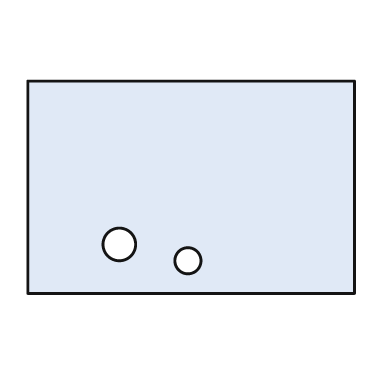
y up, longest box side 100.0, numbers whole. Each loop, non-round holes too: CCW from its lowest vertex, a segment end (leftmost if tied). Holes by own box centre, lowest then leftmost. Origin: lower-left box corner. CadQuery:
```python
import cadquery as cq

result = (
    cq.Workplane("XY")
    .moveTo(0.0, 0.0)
    .lineTo(100.0, 0.0)
    .lineTo(100.0, 65.0)
    .lineTo(0.0, 65.0)
    .close()
    .moveTo(49.0, 10.0)
    .circle(4.0)
    .moveTo(28.0, 15.0)
    .circle(5.0)
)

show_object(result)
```